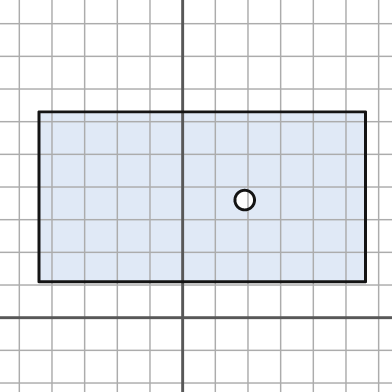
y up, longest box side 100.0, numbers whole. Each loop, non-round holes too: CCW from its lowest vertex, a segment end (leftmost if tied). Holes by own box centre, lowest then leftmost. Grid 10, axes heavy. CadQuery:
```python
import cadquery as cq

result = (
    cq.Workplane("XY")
    .moveTo(-44.0, 11.0)
    .lineTo(56.0, 11.0)
    .lineTo(56.0, 63.0)
    .lineTo(-44.0, 63.0)
    .close()
    .moveTo(19.0, 36.0)
    .circle(3.0)
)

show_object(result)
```